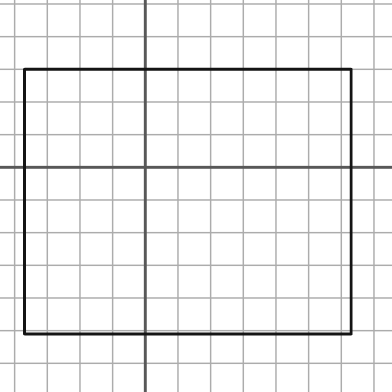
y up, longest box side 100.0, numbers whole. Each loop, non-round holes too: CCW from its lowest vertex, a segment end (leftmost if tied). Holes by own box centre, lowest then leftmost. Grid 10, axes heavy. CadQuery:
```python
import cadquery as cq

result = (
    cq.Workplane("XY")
    .moveTo(-37.0, -51.0)
    .lineTo(63.0, -51.0)
    .lineTo(63.0, 30.0)
    .lineTo(-37.0, 30.0)
    .close()
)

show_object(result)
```